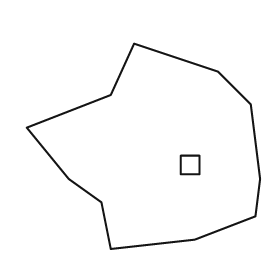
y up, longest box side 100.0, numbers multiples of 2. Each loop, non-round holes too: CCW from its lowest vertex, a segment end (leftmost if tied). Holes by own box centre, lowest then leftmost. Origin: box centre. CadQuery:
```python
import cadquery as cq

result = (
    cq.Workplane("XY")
    .moveTo(-14.0, -44.0)
    .lineTo(22.0, -40.0)
    .lineTo(48.0, -30.0)
    .lineTo(50.0, -14.0)
    .lineTo(46.0, 18.0)
    .lineTo(32.0, 32.0)
    .lineTo(-4.0, 44.0)
    .lineTo(-14.0, 22.0)
    .lineTo(-50.0, 8.0)
    .lineTo(-32.0, -14.0)
    .lineTo(-18.0, -24.0)
    .close()
    .moveTo(16.0, -12.0)
    .lineTo(24.0, -12.0)
    .lineTo(24.0, -4.0)
    .lineTo(16.0, -4.0)
    .close()
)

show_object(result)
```